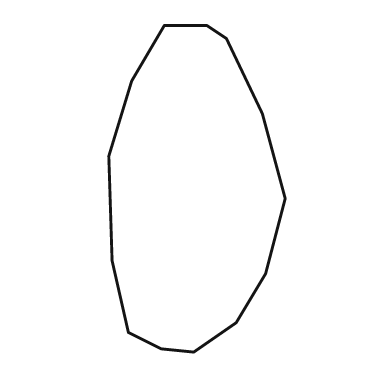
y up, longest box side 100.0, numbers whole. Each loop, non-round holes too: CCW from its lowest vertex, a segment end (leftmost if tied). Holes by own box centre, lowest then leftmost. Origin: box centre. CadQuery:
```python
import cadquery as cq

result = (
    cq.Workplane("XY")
    .moveTo(-1.0, -50.0)
    .lineTo(12.0, -41.0)
    .lineTo(21.0, -26.0)
    .lineTo(27.0, -3.0)
    .lineTo(20.0, 23.0)
    .lineTo(9.0, 46.0)
    .lineTo(3.0, 50.0)
    .lineTo(-10.0, 50.0)
    .lineTo(-20.0, 33.0)
    .lineTo(-27.0, 10.0)
    .lineTo(-26.0, -22.0)
    .lineTo(-21.0, -44.0)
    .lineTo(-11.0, -49.0)
    .close()
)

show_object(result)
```